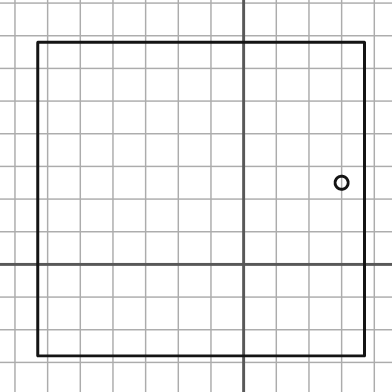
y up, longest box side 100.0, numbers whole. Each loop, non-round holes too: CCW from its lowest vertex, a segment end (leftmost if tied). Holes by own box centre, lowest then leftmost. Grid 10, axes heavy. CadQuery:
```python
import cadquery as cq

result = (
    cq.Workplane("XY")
    .moveTo(-63.0, -28.0)
    .lineTo(37.0, -28.0)
    .lineTo(37.0, 68.0)
    .lineTo(-63.0, 68.0)
    .close()
    .moveTo(30.0, 25.0)
    .circle(2.0)
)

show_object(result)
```